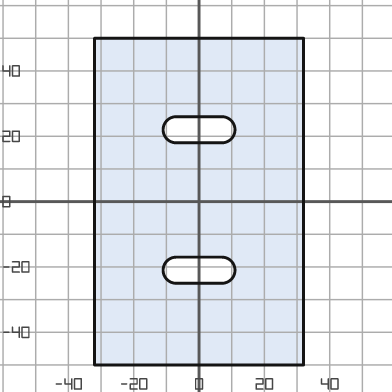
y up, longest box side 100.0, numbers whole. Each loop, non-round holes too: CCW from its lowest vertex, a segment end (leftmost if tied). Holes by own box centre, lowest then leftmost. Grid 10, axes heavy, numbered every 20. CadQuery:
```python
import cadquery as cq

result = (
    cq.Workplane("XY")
    .moveTo(-32.0, -50.0)
    .lineTo(32.0, -50.0)
    .lineTo(32.0, 50.0)
    .lineTo(-32.0, 50.0)
    .close()
    .moveTo(-7.0, -25.0)
    .lineTo(7.0, -25.0)
    .threePointArc((11.0, -21.0), (7.0, -17.0))
    .lineTo(-7.0, -17.0)
    .threePointArc((-11.0, -21.0), (-7.0, -25.0))
    .close()
    .moveTo(-7.0, 18.0)
    .lineTo(7.0, 18.0)
    .threePointArc((11.0, 22.0), (7.0, 26.0))
    .lineTo(-7.0, 26.0)
    .threePointArc((-11.0, 22.0), (-7.0, 18.0))
    .close()
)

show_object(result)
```